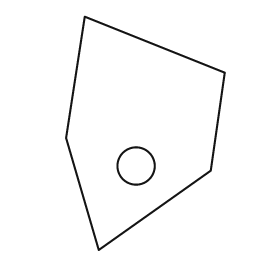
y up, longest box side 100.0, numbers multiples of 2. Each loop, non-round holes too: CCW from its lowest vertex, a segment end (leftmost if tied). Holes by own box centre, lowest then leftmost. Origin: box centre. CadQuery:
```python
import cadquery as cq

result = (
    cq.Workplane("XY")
    .moveTo(-20.0, -50.0)
    .lineTo(28.0, -16.0)
    .lineTo(34.0, 26.0)
    .lineTo(-26.0, 50.0)
    .lineTo(-34.0, -2.0)
    .close()
    .moveTo(-4.0, -14.0)
    .circle(8.0)
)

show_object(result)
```